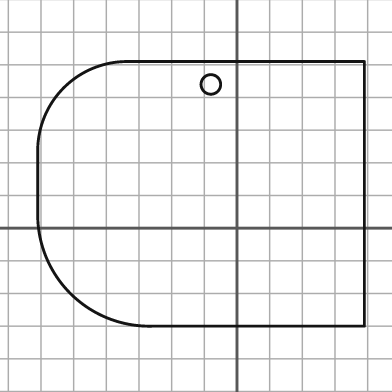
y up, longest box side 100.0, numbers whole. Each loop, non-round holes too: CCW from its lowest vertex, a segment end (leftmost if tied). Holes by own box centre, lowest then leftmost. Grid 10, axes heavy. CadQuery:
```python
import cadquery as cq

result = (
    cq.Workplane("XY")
    .moveTo(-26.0, -30.0)
    .lineTo(39.0, -30.0)
    .lineTo(39.0, 51.0)
    .lineTo(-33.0, 51.0)
    .threePointArc((-53.0, 43.0), (-61.0, 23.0))
    .lineTo(-61.0, 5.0)
    .threePointArc((-51.0, -20.0), (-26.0, -30.0))
    .close()
    .moveTo(-8.0, 44.0)
    .circle(3.0)
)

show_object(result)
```